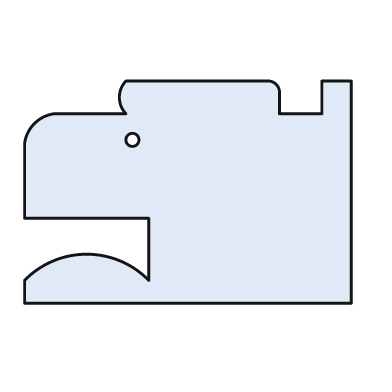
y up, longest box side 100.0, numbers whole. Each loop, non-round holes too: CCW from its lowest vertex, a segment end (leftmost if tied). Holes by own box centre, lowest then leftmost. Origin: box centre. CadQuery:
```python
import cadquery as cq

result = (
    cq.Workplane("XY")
    .moveTo(-50.0, -34.0)
    .lineTo(50.0, -34.0)
    .lineTo(50.0, 34.0)
    .lineTo(41.0, 34.0)
    .lineTo(41.0, 24.0)
    .lineTo(28.0, 24.0)
    .lineTo(28.0, 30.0)
    .threePointArc((27.0, 33.0), (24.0, 34.0))
    .lineTo(-19.0, 34.0)
    .threePointArc((-21.0, 29.0), (-19.0, 24.0))
    .lineTo(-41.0, 24.0)
    .threePointArc((-47.0, 21.0), (-50.0, 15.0))
    .lineTo(-50.0, -8.0)
    .lineTo(-12.0, -8.0)
    .lineTo(-12.0, -27.0)
    .threePointArc((-31.0, -19.0), (-50.0, -27.0))
    .close()
    .moveTo(-17.0, 16.0)
    .circle(2.0)
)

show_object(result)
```